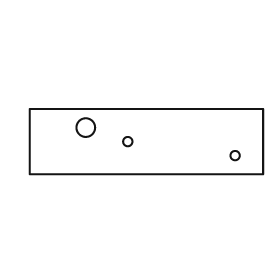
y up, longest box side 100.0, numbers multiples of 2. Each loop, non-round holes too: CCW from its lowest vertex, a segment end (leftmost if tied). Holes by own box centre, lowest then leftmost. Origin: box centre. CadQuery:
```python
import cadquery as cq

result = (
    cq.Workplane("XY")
    .moveTo(-50.0, -14.0)
    .lineTo(50.0, -14.0)
    .lineTo(50.0, 14.0)
    .lineTo(-50.0, 14.0)
    .close()
    .moveTo(38.0, -6.0)
    .circle(2.0)
    .moveTo(-8.0, 0.0)
    .circle(2.0)
    .moveTo(-26.0, 6.0)
    .circle(4.0)
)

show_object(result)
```